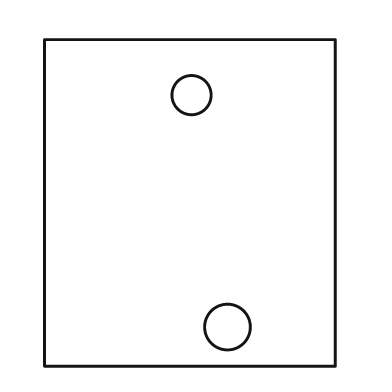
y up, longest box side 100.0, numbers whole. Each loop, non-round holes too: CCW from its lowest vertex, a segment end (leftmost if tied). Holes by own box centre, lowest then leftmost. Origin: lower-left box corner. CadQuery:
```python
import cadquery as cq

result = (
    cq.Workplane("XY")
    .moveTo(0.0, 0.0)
    .lineTo(89.0, 0.0)
    .lineTo(89.0, 100.0)
    .lineTo(0.0, 100.0)
    .close()
    .moveTo(56.0, 12.0)
    .circle(7.0)
    .moveTo(45.0, 83.0)
    .circle(6.0)
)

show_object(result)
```